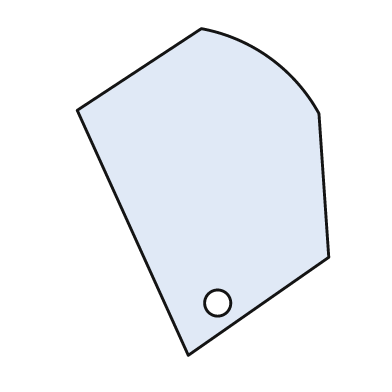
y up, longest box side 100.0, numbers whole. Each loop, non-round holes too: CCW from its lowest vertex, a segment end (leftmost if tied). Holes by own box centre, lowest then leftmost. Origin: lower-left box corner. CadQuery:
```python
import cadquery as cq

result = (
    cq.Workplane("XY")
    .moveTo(34.0, 0.0)
    .lineTo(77.0, 30.0)
    .lineTo(74.0, 74.0)
    .threePointArc((59.0, 91.0), (38.0, 100.0))
    .lineTo(0.0, 75.0)
    .close()
    .moveTo(43.0, 16.0)
    .circle(4.0)
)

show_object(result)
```